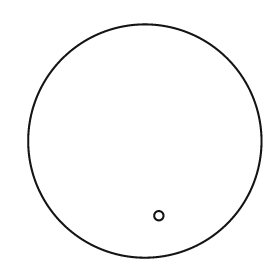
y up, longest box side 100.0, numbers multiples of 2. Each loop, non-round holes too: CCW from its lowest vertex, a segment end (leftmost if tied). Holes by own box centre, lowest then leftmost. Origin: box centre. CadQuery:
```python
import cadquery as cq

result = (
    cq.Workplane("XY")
    .moveTo(0.0, 0.0)
    .circle(50.0)
    .moveTo(6.0, -32.0)
    .circle(2.0)
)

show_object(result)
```